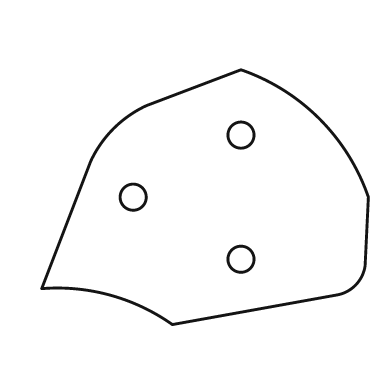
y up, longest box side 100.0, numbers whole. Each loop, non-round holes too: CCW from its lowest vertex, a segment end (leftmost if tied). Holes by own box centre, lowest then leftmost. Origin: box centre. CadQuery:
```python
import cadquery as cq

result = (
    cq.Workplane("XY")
    .moveTo(-10.0, -39.0)
    .lineTo(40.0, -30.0)
    .threePointArc((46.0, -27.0), (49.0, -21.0))
    .lineTo(50.0, 0.0)
    .threePointArc((35.0, 24.0), (11.0, 39.0))
    .lineTo(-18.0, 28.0)
    .threePointArc((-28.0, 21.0), (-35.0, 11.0))
    .lineTo(-50.0, -28.0)
    .threePointArc((-29.0, -30.0), (-10.0, -39.0))
    .close()
    .moveTo(11.0, -19.0)
    .circle(4.0)
    .moveTo(-22.0, 0.0)
    .circle(4.0)
    .moveTo(11.0, 19.0)
    .circle(4.0)
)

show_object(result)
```